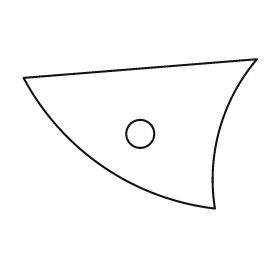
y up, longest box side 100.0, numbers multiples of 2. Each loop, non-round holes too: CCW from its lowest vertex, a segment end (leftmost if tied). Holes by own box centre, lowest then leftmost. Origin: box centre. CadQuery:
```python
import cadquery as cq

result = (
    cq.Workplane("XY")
    .moveTo(32.0, -32.0)
    .threePointArc((34.0, 2.0), (50.0, 32.0))
    .lineTo(-50.0, 24.0)
    .threePointArc((-16.0, -14.0), (32.0, -32.0))
    .close()
    .moveTo(0.0, 0.0)
    .circle(6.0)
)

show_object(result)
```